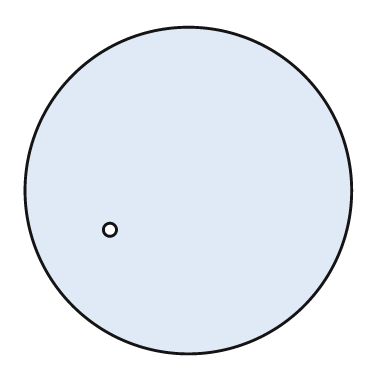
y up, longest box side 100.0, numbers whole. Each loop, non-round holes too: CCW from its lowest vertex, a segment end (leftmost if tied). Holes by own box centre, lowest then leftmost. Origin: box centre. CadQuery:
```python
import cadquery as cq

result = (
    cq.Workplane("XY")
    .moveTo(0.0, 0.0)
    .circle(50.0)
    .moveTo(-24.0, -12.0)
    .circle(2.0)
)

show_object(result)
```